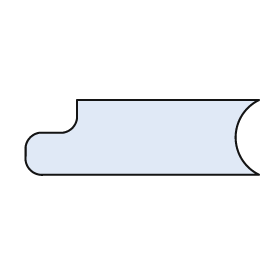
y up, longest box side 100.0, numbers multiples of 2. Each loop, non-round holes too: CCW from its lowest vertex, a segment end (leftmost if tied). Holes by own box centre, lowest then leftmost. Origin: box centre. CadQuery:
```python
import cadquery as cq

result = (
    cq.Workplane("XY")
    .moveTo(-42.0, -16.0)
    .lineTo(50.0, -16.0)
    .threePointArc((40.0, 0.0), (50.0, 16.0))
    .lineTo(-28.0, 16.0)
    .lineTo(-28.0, 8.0)
    .threePointArc((-30.0, 4.0), (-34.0, 2.0))
    .lineTo(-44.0, 2.0)
    .threePointArc((-48.0, 0.0), (-50.0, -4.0))
    .lineTo(-50.0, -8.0)
    .threePointArc((-48.0, -14.0), (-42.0, -16.0))
    .close()
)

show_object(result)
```